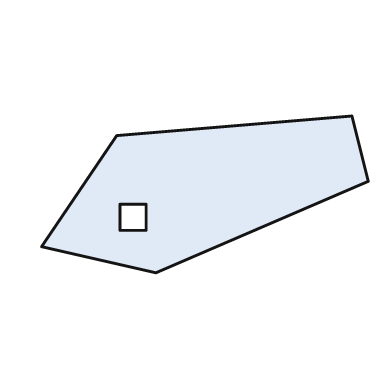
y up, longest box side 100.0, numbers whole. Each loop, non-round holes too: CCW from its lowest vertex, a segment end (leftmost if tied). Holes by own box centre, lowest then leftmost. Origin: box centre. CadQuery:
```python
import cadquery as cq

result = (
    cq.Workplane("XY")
    .moveTo(-15.0, -24.0)
    .lineTo(50.0, 4.0)
    .lineTo(45.0, 24.0)
    .lineTo(-27.0, 18.0)
    .lineTo(-50.0, -16.0)
    .close()
    .moveTo(-26.0, -11.0)
    .lineTo(-18.0, -11.0)
    .lineTo(-18.0, -3.0)
    .lineTo(-26.0, -3.0)
    .close()
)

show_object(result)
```